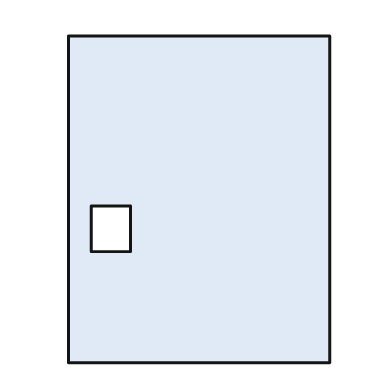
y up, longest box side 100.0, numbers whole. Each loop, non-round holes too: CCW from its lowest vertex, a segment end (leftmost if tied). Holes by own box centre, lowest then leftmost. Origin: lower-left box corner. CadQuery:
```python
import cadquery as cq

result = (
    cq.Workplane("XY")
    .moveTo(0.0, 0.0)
    .lineTo(80.0, 0.0)
    .lineTo(80.0, 100.0)
    .lineTo(0.0, 100.0)
    .close()
    .moveTo(7.0, 34.0)
    .lineTo(19.0, 34.0)
    .lineTo(19.0, 48.0)
    .lineTo(7.0, 48.0)
    .close()
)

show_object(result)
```